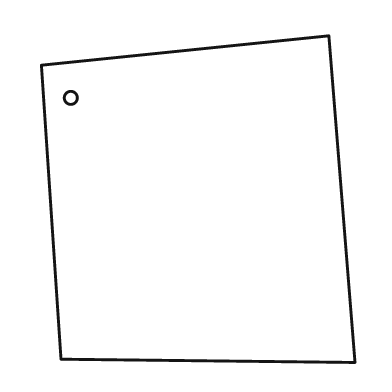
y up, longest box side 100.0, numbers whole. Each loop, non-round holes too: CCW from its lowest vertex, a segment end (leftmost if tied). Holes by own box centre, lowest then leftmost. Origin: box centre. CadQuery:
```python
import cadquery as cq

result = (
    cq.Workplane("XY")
    .moveTo(48.0, -50.0)
    .lineTo(40.0, 50.0)
    .lineTo(-48.0, 41.0)
    .lineTo(-42.0, -49.0)
    .close()
    .moveTo(-39.0, 31.0)
    .circle(2.0)
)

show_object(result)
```